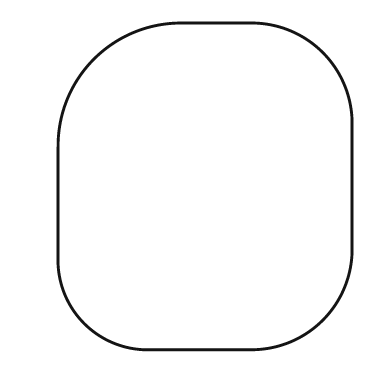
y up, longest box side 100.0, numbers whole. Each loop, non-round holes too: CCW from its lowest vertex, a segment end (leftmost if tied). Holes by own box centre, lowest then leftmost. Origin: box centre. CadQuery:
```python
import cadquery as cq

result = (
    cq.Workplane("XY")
    .moveTo(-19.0, -50.0)
    .lineTo(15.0, -50.0)
    .threePointArc((36.0, -41.0), (45.0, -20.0))
    .lineTo(45.0, 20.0)
    .threePointArc((36.0, 41.0), (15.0, 50.0))
    .lineTo(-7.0, 50.0)
    .threePointArc((-34.0, 39.0), (-45.0, 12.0))
    .lineTo(-45.0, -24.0)
    .threePointArc((-37.0, -42.0), (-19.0, -50.0))
    .close()
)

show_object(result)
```